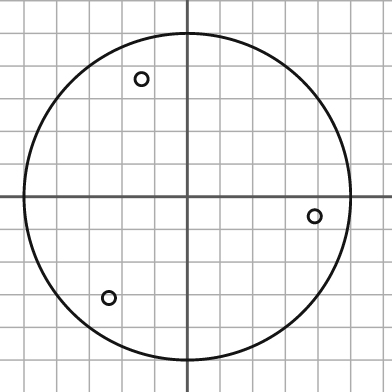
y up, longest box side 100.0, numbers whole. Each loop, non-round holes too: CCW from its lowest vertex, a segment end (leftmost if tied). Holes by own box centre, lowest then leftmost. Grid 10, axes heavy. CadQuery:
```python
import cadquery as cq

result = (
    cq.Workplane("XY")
    .moveTo(0.0, 0.0)
    .circle(50.0)
    .moveTo(-24.0, -31.0)
    .circle(2.0)
    .moveTo(39.0, -6.0)
    .circle(2.0)
    .moveTo(-14.0, 36.0)
    .circle(2.0)
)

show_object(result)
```